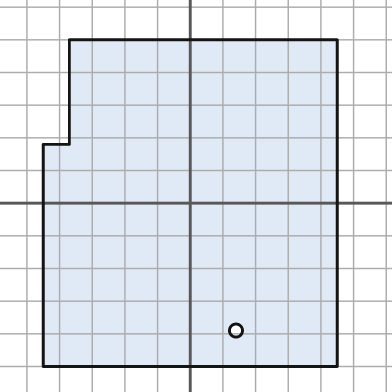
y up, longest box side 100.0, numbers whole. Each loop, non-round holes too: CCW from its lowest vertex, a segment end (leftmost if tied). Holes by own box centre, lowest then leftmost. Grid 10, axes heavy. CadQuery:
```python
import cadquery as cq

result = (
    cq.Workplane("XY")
    .moveTo(-45.0, -50.0)
    .lineTo(45.0, -50.0)
    .lineTo(45.0, 50.0)
    .lineTo(-37.0, 50.0)
    .lineTo(-37.0, 18.0)
    .lineTo(-45.0, 18.0)
    .close()
    .moveTo(14.0, -39.0)
    .circle(2.0)
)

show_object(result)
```